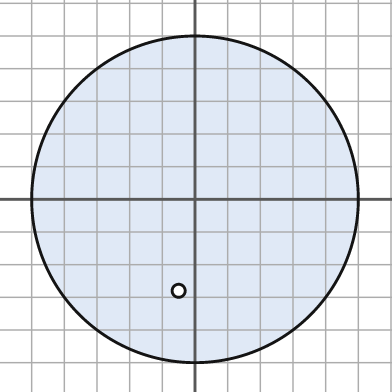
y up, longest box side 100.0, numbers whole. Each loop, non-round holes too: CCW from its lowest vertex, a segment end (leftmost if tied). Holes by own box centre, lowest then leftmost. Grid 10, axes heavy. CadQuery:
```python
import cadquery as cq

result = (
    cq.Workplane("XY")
    .moveTo(0.0, 0.0)
    .circle(50.0)
    .moveTo(-5.0, -28.0)
    .circle(2.0)
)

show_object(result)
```